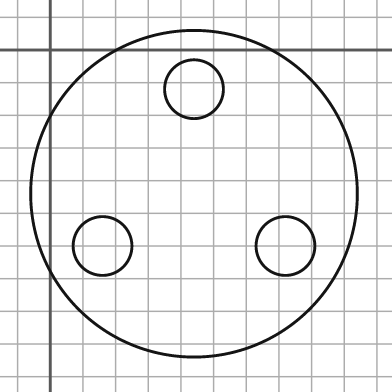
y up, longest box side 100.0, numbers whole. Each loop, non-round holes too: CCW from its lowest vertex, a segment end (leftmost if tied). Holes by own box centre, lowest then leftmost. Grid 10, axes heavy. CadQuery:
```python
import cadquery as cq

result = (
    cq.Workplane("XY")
    .moveTo(44.0, -44.0)
    .circle(50.0)
    .moveTo(16.0, -60.0)
    .circle(9.0)
    .moveTo(72.0, -60.0)
    .circle(9.0)
    .moveTo(44.0, -12.0)
    .circle(9.0)
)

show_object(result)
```